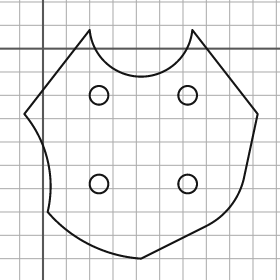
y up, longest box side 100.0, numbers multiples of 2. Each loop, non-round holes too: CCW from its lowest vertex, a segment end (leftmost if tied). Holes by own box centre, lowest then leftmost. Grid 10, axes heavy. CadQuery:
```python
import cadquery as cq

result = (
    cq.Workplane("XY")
    .moveTo(42.0, -90.0)
    .lineTo(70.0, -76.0)
    .threePointArc((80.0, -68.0), (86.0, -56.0))
    .lineTo(92.0, -28.0)
    .lineTo(64.0, 8.0)
    .threePointArc((42.0, -12.0), (20.0, 8.0))
    .lineTo(-8.0, -28.0)
    .threePointArc((2.0, -48.0), (2.0, -70.0))
    .threePointArc((20.0, -84.0), (42.0, -90.0))
    .close()
    .moveTo(24.0, -58.0)
    .circle(4.0)
    .moveTo(62.0, -58.0)
    .circle(4.0)
    .moveTo(24.0, -20.0)
    .circle(4.0)
    .moveTo(62.0, -20.0)
    .circle(4.0)
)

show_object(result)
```